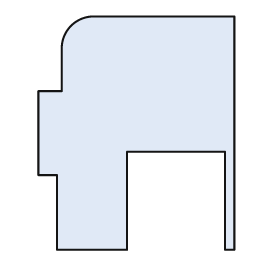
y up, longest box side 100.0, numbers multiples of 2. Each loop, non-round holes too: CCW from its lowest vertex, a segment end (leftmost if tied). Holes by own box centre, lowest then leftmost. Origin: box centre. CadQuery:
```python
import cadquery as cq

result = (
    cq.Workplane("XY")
    .moveTo(-34.0, -50.0)
    .lineTo(-4.0, -50.0)
    .lineTo(-4.0, -8.0)
    .lineTo(38.0, -8.0)
    .lineTo(38.0, -50.0)
    .lineTo(42.0, -50.0)
    .lineTo(42.0, 50.0)
    .lineTo(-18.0, 50.0)
    .threePointArc((-28.0, 46.0), (-32.0, 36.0))
    .lineTo(-32.0, 18.0)
    .lineTo(-42.0, 18.0)
    .lineTo(-42.0, -18.0)
    .lineTo(-34.0, -18.0)
    .close()
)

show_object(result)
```